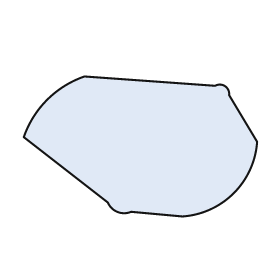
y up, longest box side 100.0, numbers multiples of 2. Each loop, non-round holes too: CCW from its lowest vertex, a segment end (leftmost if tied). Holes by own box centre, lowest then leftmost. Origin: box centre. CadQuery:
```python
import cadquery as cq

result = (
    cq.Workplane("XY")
    .moveTo(18.0, -30.0)
    .threePointArc((40.0, -20.0), (50.0, 2.0))
    .lineTo(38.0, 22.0)
    .threePointArc((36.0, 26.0), (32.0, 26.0))
    .lineTo(-24.0, 30.0)
    .threePointArc((-40.0, 20.0), (-50.0, 4.0))
    .lineTo(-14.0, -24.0)
    .threePointArc((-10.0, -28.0), (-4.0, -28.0))
    .close()
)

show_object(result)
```